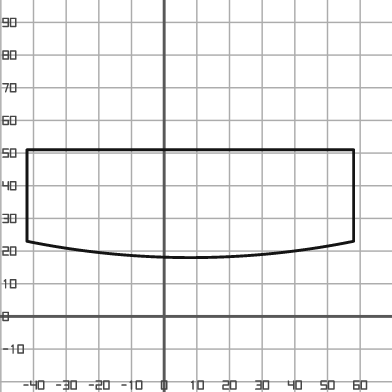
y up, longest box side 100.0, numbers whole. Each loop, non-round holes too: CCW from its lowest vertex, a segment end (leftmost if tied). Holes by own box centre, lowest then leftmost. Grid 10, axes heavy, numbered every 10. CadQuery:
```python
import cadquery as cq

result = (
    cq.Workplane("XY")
    .moveTo(-42.0, 23.0)
    .threePointArc((8.0, 18.0), (58.0, 23.0))
    .lineTo(58.0, 51.0)
    .lineTo(-42.0, 51.0)
    .close()
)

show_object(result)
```